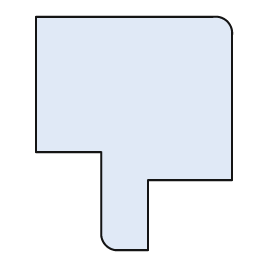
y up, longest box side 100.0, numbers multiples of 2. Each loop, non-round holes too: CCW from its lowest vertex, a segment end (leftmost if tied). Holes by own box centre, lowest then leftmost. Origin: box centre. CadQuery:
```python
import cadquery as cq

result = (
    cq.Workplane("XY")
    .moveTo(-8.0, -50.0)
    .lineTo(6.0, -50.0)
    .lineTo(6.0, -20.0)
    .lineTo(42.0, -20.0)
    .lineTo(42.0, 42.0)
    .threePointArc((40.0, 48.0), (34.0, 50.0))
    .lineTo(-42.0, 50.0)
    .lineTo(-42.0, -8.0)
    .lineTo(-14.0, -8.0)
    .lineTo(-14.0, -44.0)
    .threePointArc((-12.0, -48.0), (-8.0, -50.0))
    .close()
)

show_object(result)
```